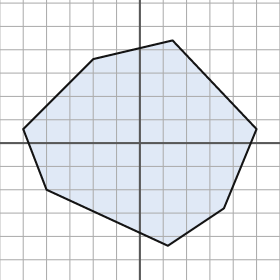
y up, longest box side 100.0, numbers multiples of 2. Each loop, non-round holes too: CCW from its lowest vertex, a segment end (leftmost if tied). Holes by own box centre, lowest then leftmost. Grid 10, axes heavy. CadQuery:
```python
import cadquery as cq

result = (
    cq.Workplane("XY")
    .moveTo(12.0, -44.0)
    .lineTo(36.0, -28.0)
    .lineTo(50.0, 6.0)
    .lineTo(14.0, 44.0)
    .lineTo(-20.0, 36.0)
    .lineTo(-50.0, 6.0)
    .lineTo(-40.0, -20.0)
    .close()
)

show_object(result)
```